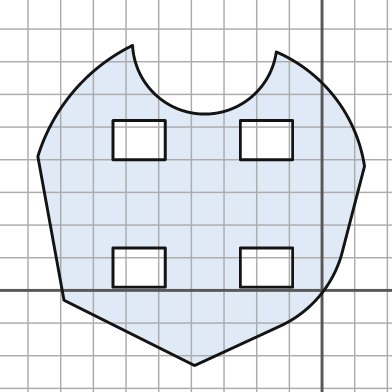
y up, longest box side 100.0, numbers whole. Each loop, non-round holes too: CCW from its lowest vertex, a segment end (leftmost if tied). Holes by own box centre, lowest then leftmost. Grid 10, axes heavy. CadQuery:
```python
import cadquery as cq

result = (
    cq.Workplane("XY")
    .moveTo(-39.0, -23.0)
    .lineTo(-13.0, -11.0)
    .threePointArc((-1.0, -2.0), (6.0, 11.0))
    .lineTo(13.0, 38.0)
    .threePointArc((4.0, 59.0), (-14.0, 73.0))
    .threePointArc((-37.0, 54.0), (-58.0, 75.0))
    .threePointArc((-76.0, 61.0), (-87.0, 41.0))
    .lineTo(-79.0, -3.0)
    .close()
    .moveTo(-64.0, 1.0)
    .lineTo(-48.0, 1.0)
    .lineTo(-48.0, 13.0)
    .lineTo(-64.0, 13.0)
    .close()
    .moveTo(-25.0, 1.0)
    .lineTo(-9.0, 1.0)
    .lineTo(-9.0, 13.0)
    .lineTo(-25.0, 13.0)
    .close()
    .moveTo(-64.0, 40.0)
    .lineTo(-48.0, 40.0)
    .lineTo(-48.0, 52.0)
    .lineTo(-64.0, 52.0)
    .close()
    .moveTo(-25.0, 40.0)
    .lineTo(-9.0, 40.0)
    .lineTo(-9.0, 52.0)
    .lineTo(-25.0, 52.0)
    .close()
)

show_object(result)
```